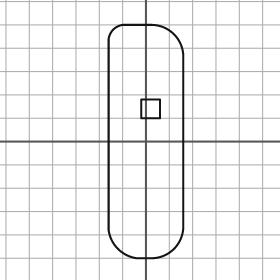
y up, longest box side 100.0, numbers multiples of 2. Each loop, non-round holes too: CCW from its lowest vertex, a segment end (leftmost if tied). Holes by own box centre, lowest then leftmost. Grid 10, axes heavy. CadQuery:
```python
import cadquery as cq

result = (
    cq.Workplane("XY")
    .moveTo(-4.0, -50.0)
    .lineTo(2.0, -50.0)
    .threePointArc((12.0, -46.0), (16.0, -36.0))
    .lineTo(16.0, 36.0)
    .threePointArc((12.0, 46.0), (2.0, 50.0))
    .lineTo(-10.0, 50.0)
    .threePointArc((-14.0, 48.0), (-16.0, 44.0))
    .lineTo(-16.0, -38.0)
    .threePointArc((-12.0, -46.0), (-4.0, -50.0))
    .close()
    .moveTo(-2.0, 10.0)
    .lineTo(6.0, 10.0)
    .lineTo(6.0, 18.0)
    .lineTo(-2.0, 18.0)
    .close()
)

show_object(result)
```